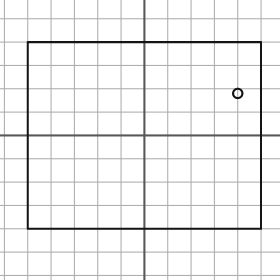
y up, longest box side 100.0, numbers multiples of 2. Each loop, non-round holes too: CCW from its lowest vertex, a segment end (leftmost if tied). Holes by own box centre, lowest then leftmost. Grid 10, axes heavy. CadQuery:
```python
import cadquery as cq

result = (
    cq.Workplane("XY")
    .moveTo(-50.0, -40.0)
    .lineTo(50.0, -40.0)
    .lineTo(50.0, 40.0)
    .lineTo(-50.0, 40.0)
    .close()
    .moveTo(40.0, 18.0)
    .circle(2.0)
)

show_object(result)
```